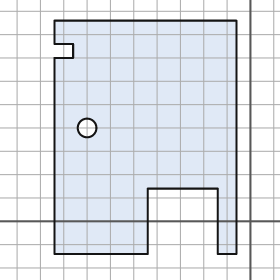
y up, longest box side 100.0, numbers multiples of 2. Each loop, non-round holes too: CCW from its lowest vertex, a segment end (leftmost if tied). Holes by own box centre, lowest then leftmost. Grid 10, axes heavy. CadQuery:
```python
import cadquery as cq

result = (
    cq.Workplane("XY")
    .moveTo(-84.0, -14.0)
    .lineTo(-44.0, -14.0)
    .lineTo(-44.0, 14.0)
    .lineTo(-14.0, 14.0)
    .lineTo(-14.0, -14.0)
    .lineTo(-6.0, -14.0)
    .lineTo(-6.0, 86.0)
    .lineTo(-84.0, 86.0)
    .lineTo(-84.0, 76.0)
    .lineTo(-76.0, 76.0)
    .lineTo(-76.0, 70.0)
    .lineTo(-84.0, 70.0)
    .close()
    .moveTo(-70.0, 40.0)
    .circle(4.0)
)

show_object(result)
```